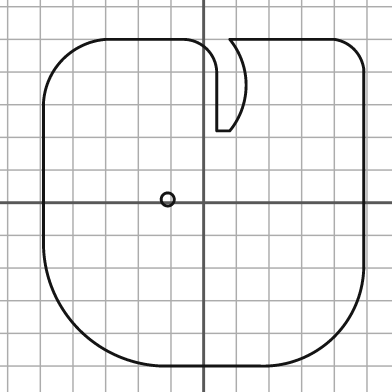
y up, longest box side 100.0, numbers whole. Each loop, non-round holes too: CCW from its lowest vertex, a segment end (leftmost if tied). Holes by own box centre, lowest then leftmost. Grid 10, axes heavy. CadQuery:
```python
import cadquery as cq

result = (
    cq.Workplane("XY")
    .moveTo(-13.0, -50.0)
    .lineTo(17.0, -50.0)
    .threePointArc((40.0, -41.0), (49.0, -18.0))
    .lineTo(49.0, 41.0)
    .threePointArc((46.0, 47.0), (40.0, 50.0))
    .lineTo(8.0, 50.0)
    .threePointArc((13.0, 36.0), (8.0, 22.0))
    .lineTo(4.0, 22.0)
    .lineTo(4.0, 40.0)
    .threePointArc((1.0, 47.0), (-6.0, 50.0))
    .lineTo(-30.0, 50.0)
    .threePointArc((-43.0, 44.0), (-49.0, 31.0))
    .lineTo(-49.0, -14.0)
    .threePointArc((-38.0, -39.0), (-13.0, -50.0))
    .close()
    .moveTo(-11.0, 1.0)
    .circle(2.0)
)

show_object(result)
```